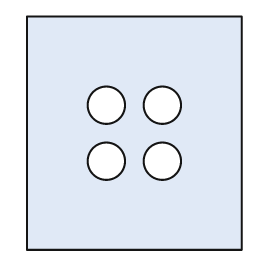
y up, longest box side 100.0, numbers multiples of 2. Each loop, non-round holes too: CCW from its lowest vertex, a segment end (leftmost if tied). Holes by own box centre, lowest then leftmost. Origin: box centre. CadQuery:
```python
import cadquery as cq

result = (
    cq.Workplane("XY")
    .moveTo(-46.0, -50.0)
    .lineTo(46.0, -50.0)
    .lineTo(46.0, 50.0)
    .lineTo(-46.0, 50.0)
    .close()
    .moveTo(-12.0, -12.0)
    .circle(8.0)
    .moveTo(12.0, -12.0)
    .circle(8.0)
    .moveTo(-12.0, 12.0)
    .circle(8.0)
    .moveTo(12.0, 12.0)
    .circle(8.0)
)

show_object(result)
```